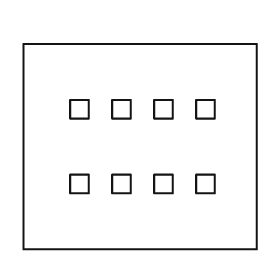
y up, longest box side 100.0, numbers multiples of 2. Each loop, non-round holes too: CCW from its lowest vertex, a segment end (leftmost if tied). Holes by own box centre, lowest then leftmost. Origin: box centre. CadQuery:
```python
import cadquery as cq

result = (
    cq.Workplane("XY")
    .moveTo(-50.0, -44.0)
    .lineTo(50.0, -44.0)
    .lineTo(50.0, 44.0)
    .lineTo(-50.0, 44.0)
    .close()
    .moveTo(-30.0, -20.0)
    .lineTo(-22.0, -20.0)
    .lineTo(-22.0, -12.0)
    .lineTo(-30.0, -12.0)
    .close()
    .moveTo(-12.0, -20.0)
    .lineTo(-4.0, -20.0)
    .lineTo(-4.0, -12.0)
    .lineTo(-12.0, -12.0)
    .close()
    .moveTo(6.0, -20.0)
    .lineTo(14.0, -20.0)
    .lineTo(14.0, -12.0)
    .lineTo(6.0, -12.0)
    .close()
    .moveTo(24.0, -20.0)
    .lineTo(32.0, -20.0)
    .lineTo(32.0, -12.0)
    .lineTo(24.0, -12.0)
    .close()
    .moveTo(-30.0, 12.0)
    .lineTo(-22.0, 12.0)
    .lineTo(-22.0, 20.0)
    .lineTo(-30.0, 20.0)
    .close()
    .moveTo(-12.0, 12.0)
    .lineTo(-4.0, 12.0)
    .lineTo(-4.0, 20.0)
    .lineTo(-12.0, 20.0)
    .close()
    .moveTo(6.0, 12.0)
    .lineTo(14.0, 12.0)
    .lineTo(14.0, 20.0)
    .lineTo(6.0, 20.0)
    .close()
    .moveTo(24.0, 12.0)
    .lineTo(32.0, 12.0)
    .lineTo(32.0, 20.0)
    .lineTo(24.0, 20.0)
    .close()
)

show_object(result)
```